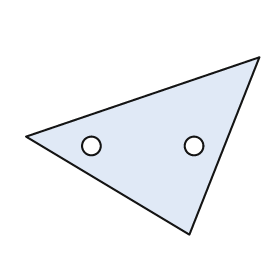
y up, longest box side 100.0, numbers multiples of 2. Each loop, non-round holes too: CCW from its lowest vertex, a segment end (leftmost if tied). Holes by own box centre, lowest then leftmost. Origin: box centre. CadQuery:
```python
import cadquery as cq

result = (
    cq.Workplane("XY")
    .moveTo(20.0, -38.0)
    .lineTo(50.0, 38.0)
    .lineTo(-50.0, 4.0)
    .close()
    .moveTo(-22.0, 0.0)
    .circle(4.0)
    .moveTo(22.0, 0.0)
    .circle(4.0)
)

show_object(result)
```